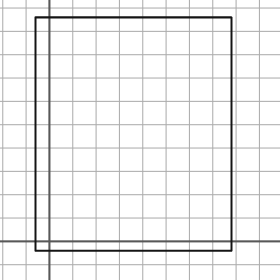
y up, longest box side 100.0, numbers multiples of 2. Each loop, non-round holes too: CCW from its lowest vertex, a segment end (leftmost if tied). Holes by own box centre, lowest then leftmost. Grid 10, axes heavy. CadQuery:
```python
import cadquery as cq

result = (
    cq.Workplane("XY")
    .moveTo(-6.0, -4.0)
    .lineTo(78.0, -4.0)
    .lineTo(78.0, 96.0)
    .lineTo(-6.0, 96.0)
    .close()
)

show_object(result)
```